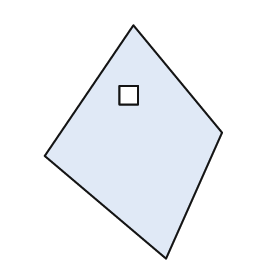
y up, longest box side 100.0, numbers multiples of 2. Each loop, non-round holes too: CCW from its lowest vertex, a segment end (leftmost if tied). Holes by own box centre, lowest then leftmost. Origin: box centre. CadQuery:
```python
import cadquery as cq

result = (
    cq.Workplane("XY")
    .moveTo(14.0, -50.0)
    .lineTo(38.0, 4.0)
    .lineTo(0.0, 50.0)
    .lineTo(-38.0, -6.0)
    .close()
    .moveTo(-6.0, 16.0)
    .lineTo(2.0, 16.0)
    .lineTo(2.0, 24.0)
    .lineTo(-6.0, 24.0)
    .close()
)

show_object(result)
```